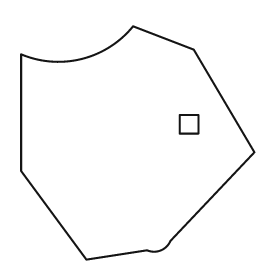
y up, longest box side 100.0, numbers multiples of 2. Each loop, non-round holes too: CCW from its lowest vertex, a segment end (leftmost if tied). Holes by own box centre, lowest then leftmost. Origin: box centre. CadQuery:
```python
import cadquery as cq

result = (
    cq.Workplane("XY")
    .moveTo(-22.0, -50.0)
    .lineTo(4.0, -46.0)
    .threePointArc((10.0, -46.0), (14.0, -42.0))
    .lineTo(50.0, -4.0)
    .lineTo(24.0, 40.0)
    .lineTo(-2.0, 50.0)
    .threePointArc((-24.0, 36.0), (-50.0, 38.0))
    .lineTo(-50.0, -12.0)
    .close()
    .moveTo(18.0, 4.0)
    .lineTo(26.0, 4.0)
    .lineTo(26.0, 12.0)
    .lineTo(18.0, 12.0)
    .close()
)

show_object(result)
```